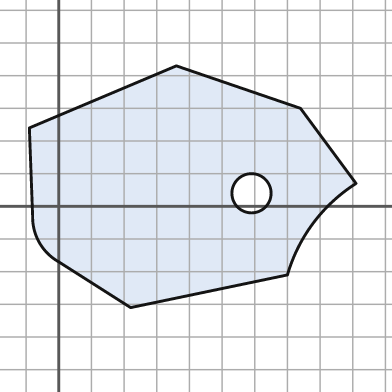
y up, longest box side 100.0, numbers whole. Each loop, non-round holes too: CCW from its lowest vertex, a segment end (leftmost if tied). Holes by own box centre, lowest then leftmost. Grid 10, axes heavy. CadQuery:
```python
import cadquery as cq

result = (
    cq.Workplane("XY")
    .moveTo(22.0, -31.0)
    .lineTo(70.0, -21.0)
    .threePointArc((78.0, -5.0), (91.0, 7.0))
    .lineTo(74.0, 30.0)
    .lineTo(36.0, 43.0)
    .lineTo(-9.0, 24.0)
    .lineTo(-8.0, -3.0)
    .threePointArc((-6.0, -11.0), (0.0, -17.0))
    .close()
    .moveTo(59.0, 4.0)
    .circle(6.0)
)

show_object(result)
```